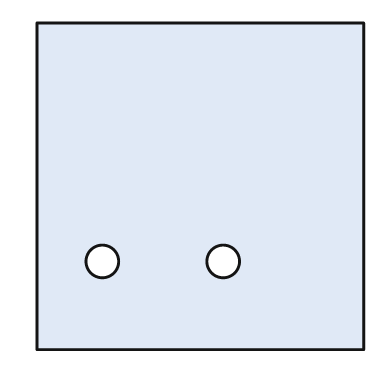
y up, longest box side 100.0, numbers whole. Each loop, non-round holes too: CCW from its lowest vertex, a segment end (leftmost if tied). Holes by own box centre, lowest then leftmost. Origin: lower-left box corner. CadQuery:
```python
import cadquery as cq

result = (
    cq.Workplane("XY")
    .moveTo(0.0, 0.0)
    .lineTo(100.0, 0.0)
    .lineTo(100.0, 100.0)
    .lineTo(0.0, 100.0)
    .close()
    .moveTo(20.0, 27.0)
    .circle(5.0)
    .moveTo(57.0, 27.0)
    .circle(5.0)
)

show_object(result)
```